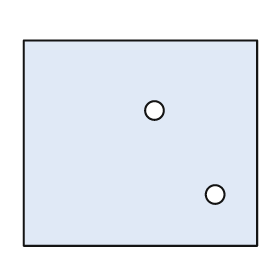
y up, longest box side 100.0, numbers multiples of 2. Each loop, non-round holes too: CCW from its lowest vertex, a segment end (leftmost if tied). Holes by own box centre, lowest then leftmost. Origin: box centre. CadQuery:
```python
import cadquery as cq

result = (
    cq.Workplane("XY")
    .moveTo(-50.0, -44.0)
    .lineTo(50.0, -44.0)
    .lineTo(50.0, 44.0)
    .lineTo(-50.0, 44.0)
    .close()
    .moveTo(32.0, -22.0)
    .circle(4.0)
    .moveTo(6.0, 14.0)
    .circle(4.0)
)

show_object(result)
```